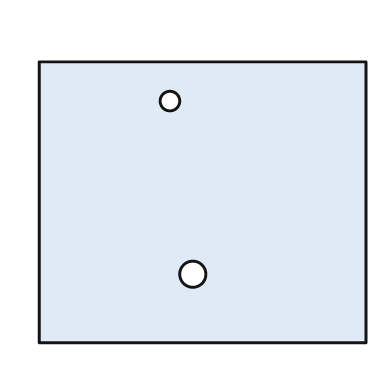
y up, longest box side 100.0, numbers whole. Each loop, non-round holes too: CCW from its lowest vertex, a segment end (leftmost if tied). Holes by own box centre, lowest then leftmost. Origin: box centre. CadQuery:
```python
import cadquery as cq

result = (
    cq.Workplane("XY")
    .moveTo(-50.0, -43.0)
    .lineTo(50.0, -43.0)
    .lineTo(50.0, 43.0)
    .lineTo(-50.0, 43.0)
    .close()
    .moveTo(-3.0, -22.0)
    .circle(4.0)
    .moveTo(-10.0, 31.0)
    .circle(3.0)
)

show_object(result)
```